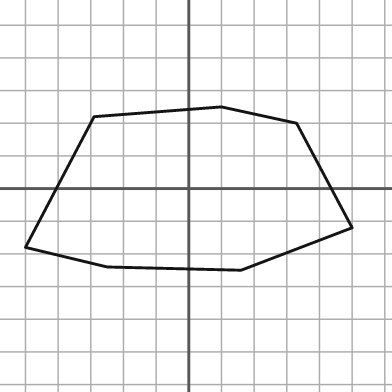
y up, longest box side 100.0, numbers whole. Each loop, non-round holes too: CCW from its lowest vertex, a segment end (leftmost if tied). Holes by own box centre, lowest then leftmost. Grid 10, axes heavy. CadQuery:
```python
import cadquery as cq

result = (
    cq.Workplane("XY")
    .moveTo(16.0, -25.0)
    .lineTo(50.0, -12.0)
    .lineTo(33.0, 20.0)
    .lineTo(10.0, 25.0)
    .lineTo(-29.0, 22.0)
    .lineTo(-50.0, -18.0)
    .lineTo(-25.0, -24.0)
    .close()
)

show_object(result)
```